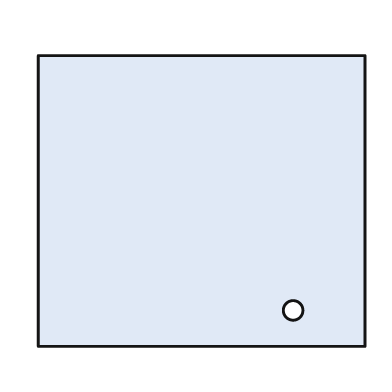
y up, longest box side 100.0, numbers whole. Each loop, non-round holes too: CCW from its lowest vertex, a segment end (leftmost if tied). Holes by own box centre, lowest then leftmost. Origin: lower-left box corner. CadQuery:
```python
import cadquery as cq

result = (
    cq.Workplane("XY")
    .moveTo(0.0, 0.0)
    .lineTo(100.0, 0.0)
    .lineTo(100.0, 89.0)
    .lineTo(0.0, 89.0)
    .close()
    .moveTo(78.0, 11.0)
    .circle(3.0)
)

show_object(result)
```